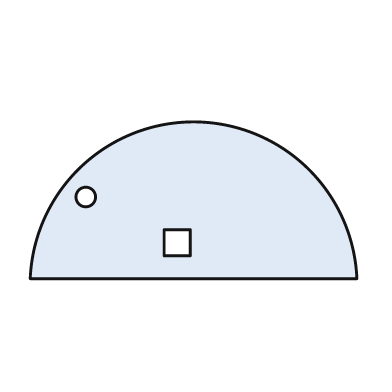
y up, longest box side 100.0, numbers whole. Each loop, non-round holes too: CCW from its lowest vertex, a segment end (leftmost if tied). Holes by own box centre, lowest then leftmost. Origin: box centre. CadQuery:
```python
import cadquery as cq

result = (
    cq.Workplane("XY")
    .moveTo(-50.0, -24.0)
    .lineTo(50.0, -24.0)
    .threePointArc((0.0, 24.0), (-50.0, -24.0))
    .close()
    .moveTo(-9.0, -17.0)
    .lineTo(-1.0, -17.0)
    .lineTo(-1.0, -9.0)
    .lineTo(-9.0, -9.0)
    .close()
    .moveTo(-33.0, 1.0)
    .circle(3.0)
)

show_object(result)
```